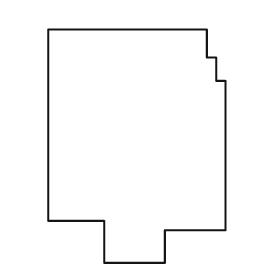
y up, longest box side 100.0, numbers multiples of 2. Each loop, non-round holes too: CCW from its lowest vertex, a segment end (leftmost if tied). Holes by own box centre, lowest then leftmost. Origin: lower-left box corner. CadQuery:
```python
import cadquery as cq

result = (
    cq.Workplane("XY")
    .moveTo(24.0, 0.0)
    .lineTo(50.0, 0.0)
    .lineTo(50.0, 14.0)
    .lineTo(76.0, 14.0)
    .lineTo(76.0, 78.0)
    .lineTo(72.0, 78.0)
    .lineTo(72.0, 88.0)
    .lineTo(68.0, 88.0)
    .lineTo(68.0, 100.0)
    .lineTo(0.0, 100.0)
    .lineTo(0.0, 18.0)
    .lineTo(24.0, 18.0)
    .close()
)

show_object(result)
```